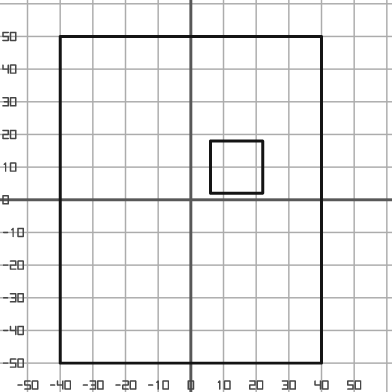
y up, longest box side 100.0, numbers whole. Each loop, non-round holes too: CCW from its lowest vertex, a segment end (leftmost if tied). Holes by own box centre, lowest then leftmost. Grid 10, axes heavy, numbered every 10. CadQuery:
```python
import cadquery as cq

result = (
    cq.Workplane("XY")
    .moveTo(-40.0, -50.0)
    .lineTo(40.0, -50.0)
    .lineTo(40.0, 50.0)
    .lineTo(-40.0, 50.0)
    .close()
    .moveTo(6.0, 2.0)
    .lineTo(22.0, 2.0)
    .lineTo(22.0, 18.0)
    .lineTo(6.0, 18.0)
    .close()
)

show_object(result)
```